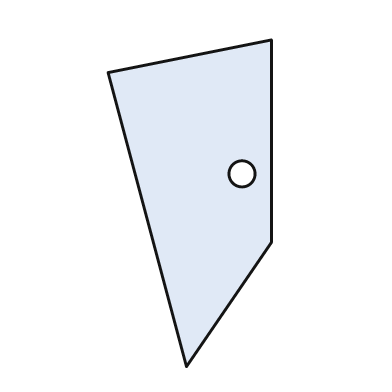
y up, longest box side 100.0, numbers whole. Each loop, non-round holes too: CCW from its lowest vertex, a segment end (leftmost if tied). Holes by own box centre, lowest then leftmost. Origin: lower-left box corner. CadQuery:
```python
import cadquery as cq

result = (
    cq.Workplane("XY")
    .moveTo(24.0, 0.0)
    .lineTo(50.0, 38.0)
    .lineTo(50.0, 100.0)
    .lineTo(0.0, 90.0)
    .close()
    .moveTo(41.0, 59.0)
    .circle(4.0)
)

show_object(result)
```